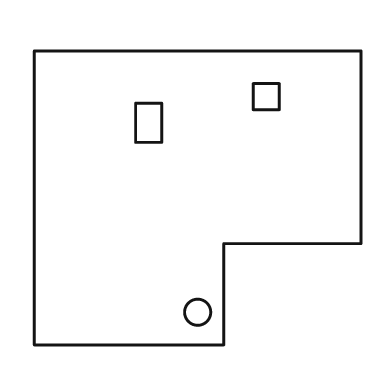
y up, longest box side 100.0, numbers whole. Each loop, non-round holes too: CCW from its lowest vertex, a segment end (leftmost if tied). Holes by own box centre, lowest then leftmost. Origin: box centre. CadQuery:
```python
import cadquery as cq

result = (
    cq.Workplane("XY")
    .moveTo(-50.0, -45.0)
    .lineTo(8.0, -45.0)
    .lineTo(8.0, -14.0)
    .lineTo(50.0, -14.0)
    .lineTo(50.0, 45.0)
    .lineTo(-50.0, 45.0)
    .close()
    .moveTo(0.0, -35.0)
    .circle(4.0)
    .moveTo(-19.0, 17.0)
    .lineTo(-11.0, 17.0)
    .lineTo(-11.0, 29.0)
    .lineTo(-19.0, 29.0)
    .close()
    .moveTo(17.0, 27.0)
    .lineTo(25.0, 27.0)
    .lineTo(25.0, 35.0)
    .lineTo(17.0, 35.0)
    .close()
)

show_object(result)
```